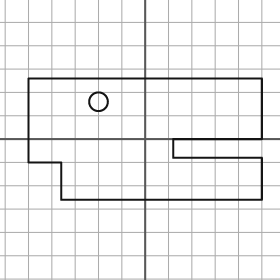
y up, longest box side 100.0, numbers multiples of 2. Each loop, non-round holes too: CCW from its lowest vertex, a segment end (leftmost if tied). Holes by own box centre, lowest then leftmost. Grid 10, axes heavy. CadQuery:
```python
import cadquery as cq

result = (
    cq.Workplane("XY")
    .moveTo(-36.0, -26.0)
    .lineTo(50.0, -26.0)
    .lineTo(50.0, -8.0)
    .lineTo(12.0, -8.0)
    .lineTo(12.0, 0.0)
    .lineTo(50.0, 0.0)
    .lineTo(50.0, 26.0)
    .lineTo(-50.0, 26.0)
    .lineTo(-50.0, -10.0)
    .lineTo(-36.0, -10.0)
    .close()
    .moveTo(-20.0, 16.0)
    .circle(4.0)
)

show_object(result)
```